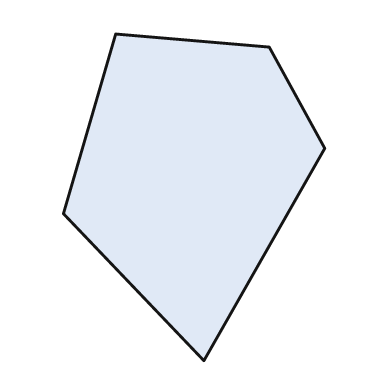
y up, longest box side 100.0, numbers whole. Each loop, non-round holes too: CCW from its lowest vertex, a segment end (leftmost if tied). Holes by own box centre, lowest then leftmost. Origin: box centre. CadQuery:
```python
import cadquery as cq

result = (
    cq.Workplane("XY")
    .moveTo(3.0, -50.0)
    .lineTo(40.0, 15.0)
    .lineTo(23.0, 46.0)
    .lineTo(-24.0, 50.0)
    .lineTo(-40.0, -5.0)
    .close()
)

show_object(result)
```